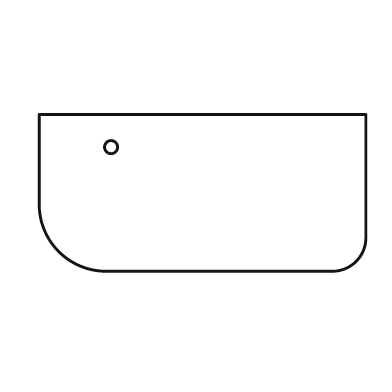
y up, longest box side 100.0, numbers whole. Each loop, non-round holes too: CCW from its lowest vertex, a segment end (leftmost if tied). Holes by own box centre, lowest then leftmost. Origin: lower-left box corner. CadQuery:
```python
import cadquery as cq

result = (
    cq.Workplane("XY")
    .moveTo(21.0, 0.0)
    .lineTo(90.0, 0.0)
    .threePointArc((97.0, 3.0), (100.0, 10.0))
    .lineTo(100.0, 48.0)
    .lineTo(0.0, 48.0)
    .lineTo(0.0, 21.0)
    .threePointArc((6.0, 6.0), (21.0, 0.0))
    .close()
    .moveTo(22.0, 38.0)
    .circle(2.0)
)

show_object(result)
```